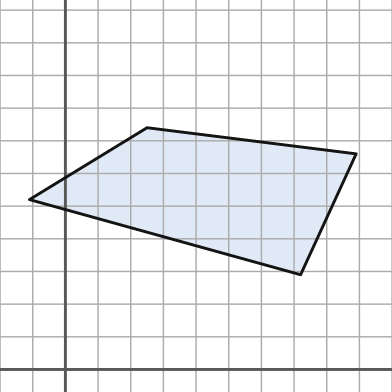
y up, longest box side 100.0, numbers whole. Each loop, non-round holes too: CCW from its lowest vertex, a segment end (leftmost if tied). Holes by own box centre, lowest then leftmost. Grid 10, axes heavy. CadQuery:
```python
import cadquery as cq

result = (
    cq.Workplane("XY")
    .moveTo(72.0, 29.0)
    .lineTo(89.0, 66.0)
    .lineTo(25.0, 74.0)
    .lineTo(-11.0, 52.0)
    .close()
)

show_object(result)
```